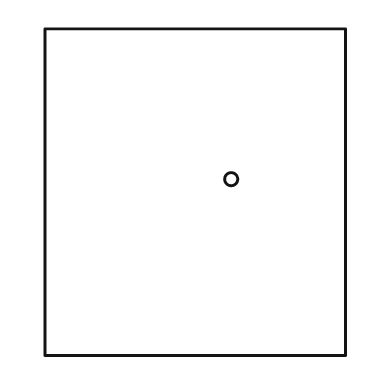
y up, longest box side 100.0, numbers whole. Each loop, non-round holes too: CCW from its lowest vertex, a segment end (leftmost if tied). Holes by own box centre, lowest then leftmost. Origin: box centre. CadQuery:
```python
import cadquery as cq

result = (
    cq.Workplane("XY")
    .moveTo(-46.0, -50.0)
    .lineTo(46.0, -50.0)
    .lineTo(46.0, 50.0)
    .lineTo(-46.0, 50.0)
    .close()
    .moveTo(11.0, 4.0)
    .circle(2.0)
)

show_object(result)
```